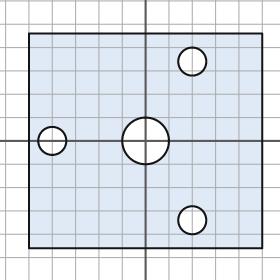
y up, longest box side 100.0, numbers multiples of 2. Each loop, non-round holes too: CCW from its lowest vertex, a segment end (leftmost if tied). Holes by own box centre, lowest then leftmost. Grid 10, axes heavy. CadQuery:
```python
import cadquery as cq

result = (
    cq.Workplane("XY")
    .moveTo(-50.0, -46.0)
    .lineTo(50.0, -46.0)
    .lineTo(50.0, 46.0)
    .lineTo(-50.0, 46.0)
    .close()
    .moveTo(20.0, -34.0)
    .circle(6.0)
    .moveTo(-40.0, 0.0)
    .circle(6.0)
    .moveTo(0.0, 0.0)
    .circle(10.0)
    .moveTo(20.0, 34.0)
    .circle(6.0)
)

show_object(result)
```